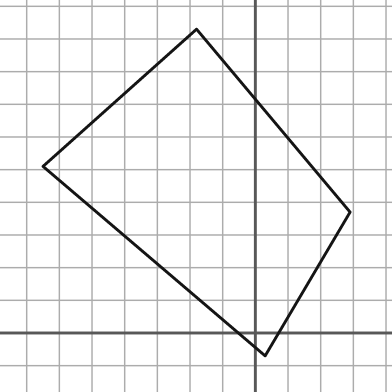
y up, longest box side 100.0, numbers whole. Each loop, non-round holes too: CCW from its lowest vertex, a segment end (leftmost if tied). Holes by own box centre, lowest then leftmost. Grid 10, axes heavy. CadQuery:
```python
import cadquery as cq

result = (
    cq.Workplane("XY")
    .moveTo(3.0, -7.0)
    .lineTo(29.0, 37.0)
    .lineTo(-18.0, 93.0)
    .lineTo(-65.0, 51.0)
    .close()
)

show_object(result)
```